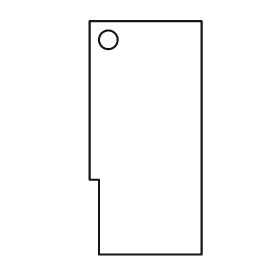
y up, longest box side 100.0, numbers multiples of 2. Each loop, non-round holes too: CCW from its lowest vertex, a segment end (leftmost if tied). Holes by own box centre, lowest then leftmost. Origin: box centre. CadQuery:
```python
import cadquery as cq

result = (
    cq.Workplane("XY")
    .moveTo(-20.0, -50.0)
    .lineTo(24.0, -50.0)
    .lineTo(24.0, 50.0)
    .lineTo(-24.0, 50.0)
    .lineTo(-24.0, -18.0)
    .lineTo(-20.0, -18.0)
    .close()
    .moveTo(-16.0, 42.0)
    .circle(4.0)
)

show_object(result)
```